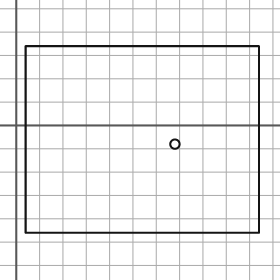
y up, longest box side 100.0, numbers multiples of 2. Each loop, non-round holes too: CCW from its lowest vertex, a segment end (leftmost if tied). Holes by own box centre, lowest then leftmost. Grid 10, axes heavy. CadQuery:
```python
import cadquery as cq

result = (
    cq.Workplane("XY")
    .moveTo(4.0, -46.0)
    .lineTo(104.0, -46.0)
    .lineTo(104.0, 34.0)
    .lineTo(4.0, 34.0)
    .close()
    .moveTo(68.0, -8.0)
    .circle(2.0)
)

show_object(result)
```